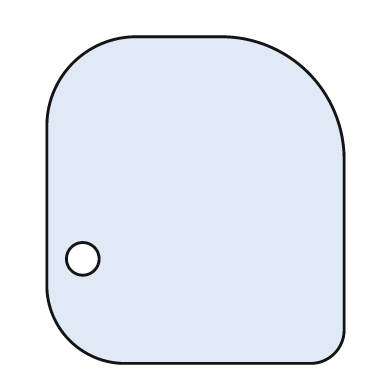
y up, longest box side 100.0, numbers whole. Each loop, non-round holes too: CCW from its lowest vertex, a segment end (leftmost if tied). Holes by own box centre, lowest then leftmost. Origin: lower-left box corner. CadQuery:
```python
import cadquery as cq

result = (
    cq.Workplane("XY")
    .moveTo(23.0, 0.0)
    .lineTo(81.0, 0.0)
    .threePointArc((88.0, 3.0), (91.0, 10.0))
    .lineTo(91.0, 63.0)
    .threePointArc((80.0, 89.0), (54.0, 100.0))
    .lineTo(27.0, 100.0)
    .threePointArc((8.0, 92.0), (0.0, 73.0))
    .lineTo(0.0, 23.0)
    .threePointArc((7.0, 7.0), (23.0, 0.0))
    .close()
    .moveTo(11.0, 32.0)
    .circle(5.0)
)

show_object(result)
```